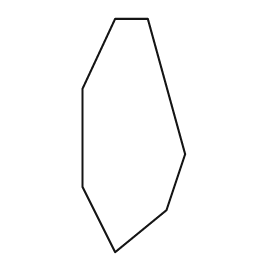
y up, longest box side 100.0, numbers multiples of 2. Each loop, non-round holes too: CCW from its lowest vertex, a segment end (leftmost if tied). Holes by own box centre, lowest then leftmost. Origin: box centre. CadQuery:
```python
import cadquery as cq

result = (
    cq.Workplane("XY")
    .moveTo(-8.0, -50.0)
    .lineTo(14.0, -32.0)
    .lineTo(22.0, -8.0)
    .lineTo(6.0, 50.0)
    .lineTo(-8.0, 50.0)
    .lineTo(-22.0, 20.0)
    .lineTo(-22.0, -22.0)
    .close()
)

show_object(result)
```